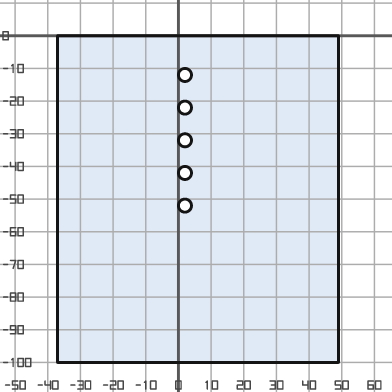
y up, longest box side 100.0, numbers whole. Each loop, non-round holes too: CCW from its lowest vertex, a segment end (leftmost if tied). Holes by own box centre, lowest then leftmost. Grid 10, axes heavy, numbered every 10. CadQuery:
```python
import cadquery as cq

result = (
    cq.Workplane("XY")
    .moveTo(-37.0, -100.0)
    .lineTo(49.0, -100.0)
    .lineTo(49.0, 0.0)
    .lineTo(-37.0, 0.0)
    .close()
    .moveTo(2.0, -52.0)
    .circle(2.0)
    .moveTo(2.0, -42.0)
    .circle(2.0)
    .moveTo(2.0, -32.0)
    .circle(2.0)
    .moveTo(2.0, -22.0)
    .circle(2.0)
    .moveTo(2.0, -12.0)
    .circle(2.0)
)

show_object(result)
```